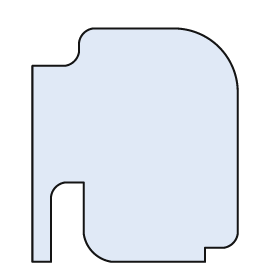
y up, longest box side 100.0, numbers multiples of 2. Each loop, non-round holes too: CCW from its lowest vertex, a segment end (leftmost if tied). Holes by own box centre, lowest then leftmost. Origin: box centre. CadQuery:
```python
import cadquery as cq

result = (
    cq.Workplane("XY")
    .moveTo(-44.0, -50.0)
    .lineTo(-36.0, -50.0)
    .lineTo(-36.0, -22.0)
    .threePointArc((-34.0, -18.0), (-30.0, -16.0))
    .lineTo(-22.0, -16.0)
    .lineTo(-22.0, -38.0)
    .threePointArc((-18.0, -46.0), (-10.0, -50.0))
    .lineTo(30.0, -50.0)
    .lineTo(30.0, -44.0)
    .lineTo(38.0, -44.0)
    .threePointArc((42.0, -42.0), (44.0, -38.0))
    .lineTo(44.0, 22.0)
    .threePointArc((36.0, 42.0), (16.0, 50.0))
    .lineTo(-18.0, 50.0)
    .threePointArc((-22.0, 48.0), (-24.0, 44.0))
    .lineTo(-24.0, 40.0)
    .threePointArc((-26.0, 36.0), (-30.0, 34.0))
    .lineTo(-44.0, 34.0)
    .close()
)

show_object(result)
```